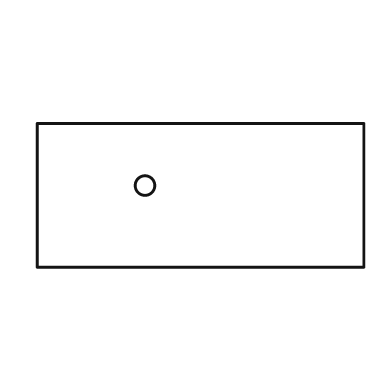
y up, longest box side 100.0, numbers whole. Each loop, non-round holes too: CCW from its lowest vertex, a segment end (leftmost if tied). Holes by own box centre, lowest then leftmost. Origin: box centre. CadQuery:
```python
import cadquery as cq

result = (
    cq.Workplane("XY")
    .moveTo(-50.0, -22.0)
    .lineTo(50.0, -22.0)
    .lineTo(50.0, 22.0)
    .lineTo(-50.0, 22.0)
    .close()
    .moveTo(-17.0, 3.0)
    .circle(3.0)
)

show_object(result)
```